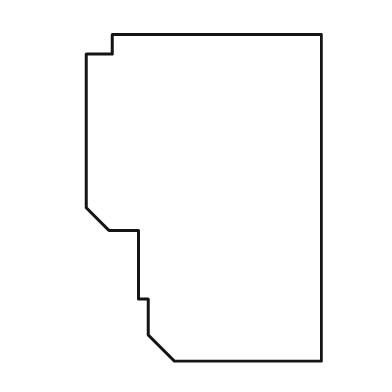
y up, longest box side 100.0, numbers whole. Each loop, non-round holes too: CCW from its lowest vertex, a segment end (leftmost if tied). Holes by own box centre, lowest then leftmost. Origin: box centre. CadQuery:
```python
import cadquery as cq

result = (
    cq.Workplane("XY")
    .moveTo(-9.0, -50.0)
    .lineTo(36.0, -50.0)
    .lineTo(36.0, 50.0)
    .lineTo(-28.0, 50.0)
    .lineTo(-28.0, 44.0)
    .lineTo(-36.0, 44.0)
    .lineTo(-36.0, -3.0)
    .lineTo(-29.0, -10.0)
    .lineTo(-20.0, -10.0)
    .lineTo(-20.0, -31.0)
    .lineTo(-17.0, -31.0)
    .lineTo(-17.0, -42.0)
    .close()
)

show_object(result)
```